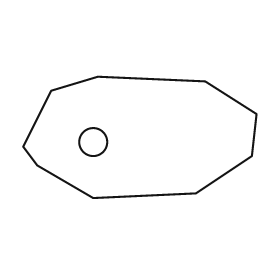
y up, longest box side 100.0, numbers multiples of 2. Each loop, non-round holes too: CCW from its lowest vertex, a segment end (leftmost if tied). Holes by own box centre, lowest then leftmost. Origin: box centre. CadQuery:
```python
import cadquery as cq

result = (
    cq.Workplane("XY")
    .moveTo(-20.0, -26.0)
    .lineTo(24.0, -24.0)
    .lineTo(48.0, -8.0)
    .lineTo(50.0, 10.0)
    .lineTo(28.0, 24.0)
    .lineTo(-18.0, 26.0)
    .lineTo(-38.0, 20.0)
    .lineTo(-50.0, -4.0)
    .lineTo(-44.0, -12.0)
    .close()
    .moveTo(-20.0, -2.0)
    .circle(6.0)
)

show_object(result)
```